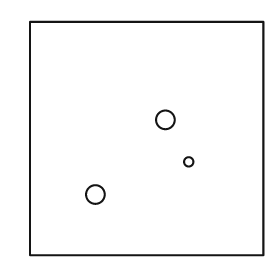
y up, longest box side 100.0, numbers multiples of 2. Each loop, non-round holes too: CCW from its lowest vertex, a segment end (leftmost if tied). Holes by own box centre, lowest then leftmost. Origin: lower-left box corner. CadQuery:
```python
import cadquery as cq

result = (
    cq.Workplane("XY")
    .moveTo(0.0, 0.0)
    .lineTo(100.0, 0.0)
    .lineTo(100.0, 100.0)
    .lineTo(0.0, 100.0)
    .close()
    .moveTo(28.0, 26.0)
    .circle(4.0)
    .moveTo(68.0, 40.0)
    .circle(2.0)
    .moveTo(58.0, 58.0)
    .circle(4.0)
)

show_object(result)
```